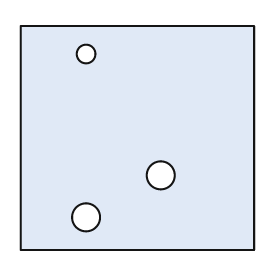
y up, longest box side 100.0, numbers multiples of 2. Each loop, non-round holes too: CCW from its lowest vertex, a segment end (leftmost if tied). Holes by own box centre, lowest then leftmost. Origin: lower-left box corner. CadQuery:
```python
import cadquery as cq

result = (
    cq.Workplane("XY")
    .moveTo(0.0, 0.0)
    .lineTo(100.0, 0.0)
    .lineTo(100.0, 96.0)
    .lineTo(0.0, 96.0)
    .close()
    .moveTo(28.0, 14.0)
    .circle(6.0)
    .moveTo(60.0, 32.0)
    .circle(6.0)
    .moveTo(28.0, 84.0)
    .circle(4.0)
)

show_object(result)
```